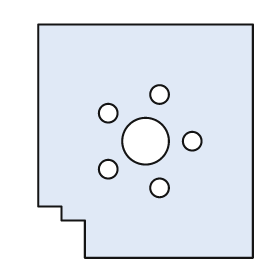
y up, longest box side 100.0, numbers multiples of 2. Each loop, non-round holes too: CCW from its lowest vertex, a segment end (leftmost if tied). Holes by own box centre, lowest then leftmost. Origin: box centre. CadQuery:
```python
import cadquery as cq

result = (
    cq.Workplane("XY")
    .moveTo(-26.0, -50.0)
    .lineTo(46.0, -50.0)
    .lineTo(46.0, 50.0)
    .lineTo(-46.0, 50.0)
    .lineTo(-46.0, -28.0)
    .lineTo(-36.0, -28.0)
    .lineTo(-36.0, -34.0)
    .lineTo(-26.0, -34.0)
    .close()
    .moveTo(6.0, -20.0)
    .circle(4.0)
    .moveTo(-16.0, -12.0)
    .circle(4.0)
    .moveTo(0.0, 0.0)
    .circle(10.0)
    .moveTo(20.0, 0.0)
    .circle(4.0)
    .moveTo(-16.0, 12.0)
    .circle(4.0)
    .moveTo(6.0, 20.0)
    .circle(4.0)
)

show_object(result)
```